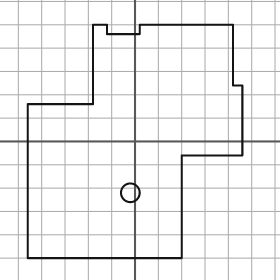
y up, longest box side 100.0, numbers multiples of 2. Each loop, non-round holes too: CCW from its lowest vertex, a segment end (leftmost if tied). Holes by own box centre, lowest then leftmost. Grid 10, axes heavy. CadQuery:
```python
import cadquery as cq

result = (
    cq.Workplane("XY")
    .moveTo(-46.0, -50.0)
    .lineTo(20.0, -50.0)
    .lineTo(20.0, -6.0)
    .lineTo(46.0, -6.0)
    .lineTo(46.0, 24.0)
    .lineTo(42.0, 24.0)
    .lineTo(42.0, 50.0)
    .lineTo(2.0, 50.0)
    .lineTo(2.0, 46.0)
    .lineTo(-12.0, 46.0)
    .lineTo(-12.0, 50.0)
    .lineTo(-18.0, 50.0)
    .lineTo(-18.0, 16.0)
    .lineTo(-46.0, 16.0)
    .close()
    .moveTo(-2.0, -22.0)
    .circle(4.0)
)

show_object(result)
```